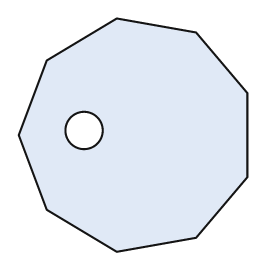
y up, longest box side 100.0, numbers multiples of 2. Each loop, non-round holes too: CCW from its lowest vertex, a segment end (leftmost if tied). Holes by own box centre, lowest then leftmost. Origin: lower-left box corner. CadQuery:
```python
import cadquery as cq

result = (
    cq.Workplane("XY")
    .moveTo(42.0, 0.0)
    .lineTo(76.0, 6.0)
    .lineTo(98.0, 32.0)
    .lineTo(98.0, 68.0)
    .lineTo(76.0, 94.0)
    .lineTo(42.0, 100.0)
    .lineTo(12.0, 82.0)
    .lineTo(0.0, 50.0)
    .lineTo(12.0, 18.0)
    .close()
    .moveTo(28.0, 52.0)
    .circle(8.0)
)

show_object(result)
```